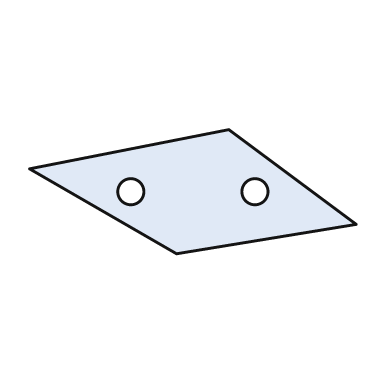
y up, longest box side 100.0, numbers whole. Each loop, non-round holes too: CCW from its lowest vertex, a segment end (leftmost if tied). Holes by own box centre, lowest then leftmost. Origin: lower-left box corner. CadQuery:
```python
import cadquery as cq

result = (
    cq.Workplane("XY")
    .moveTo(45.0, 0.0)
    .lineTo(100.0, 9.0)
    .lineTo(61.0, 38.0)
    .lineTo(0.0, 26.0)
    .close()
    .moveTo(31.0, 19.0)
    .circle(4.0)
    .moveTo(69.0, 19.0)
    .circle(4.0)
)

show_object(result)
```